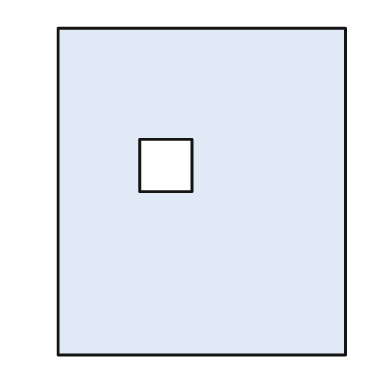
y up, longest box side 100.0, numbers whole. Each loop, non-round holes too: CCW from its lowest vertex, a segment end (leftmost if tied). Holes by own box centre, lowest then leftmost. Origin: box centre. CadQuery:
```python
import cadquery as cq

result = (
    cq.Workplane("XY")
    .moveTo(-44.0, -50.0)
    .lineTo(44.0, -50.0)
    .lineTo(44.0, 50.0)
    .lineTo(-44.0, 50.0)
    .close()
    .moveTo(-19.0, 0.0)
    .lineTo(-3.0, 0.0)
    .lineTo(-3.0, 16.0)
    .lineTo(-19.0, 16.0)
    .close()
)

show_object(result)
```